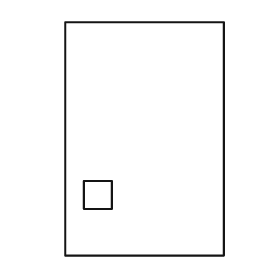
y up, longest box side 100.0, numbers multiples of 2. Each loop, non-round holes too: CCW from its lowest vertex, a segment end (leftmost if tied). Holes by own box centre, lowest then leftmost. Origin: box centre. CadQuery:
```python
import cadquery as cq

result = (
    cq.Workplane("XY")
    .moveTo(-34.0, -50.0)
    .lineTo(34.0, -50.0)
    .lineTo(34.0, 50.0)
    .lineTo(-34.0, 50.0)
    .close()
    .moveTo(-26.0, -30.0)
    .lineTo(-14.0, -30.0)
    .lineTo(-14.0, -18.0)
    .lineTo(-26.0, -18.0)
    .close()
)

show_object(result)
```